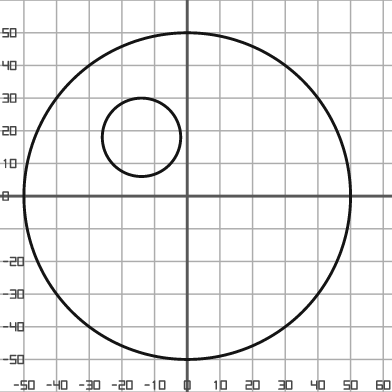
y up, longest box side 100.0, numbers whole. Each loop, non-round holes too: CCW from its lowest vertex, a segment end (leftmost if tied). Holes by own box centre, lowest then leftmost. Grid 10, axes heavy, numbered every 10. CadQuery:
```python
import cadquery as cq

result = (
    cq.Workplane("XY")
    .moveTo(0.0, 0.0)
    .circle(50.0)
    .moveTo(-14.0, 18.0)
    .circle(12.0)
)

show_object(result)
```